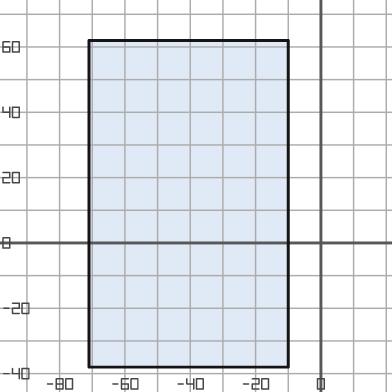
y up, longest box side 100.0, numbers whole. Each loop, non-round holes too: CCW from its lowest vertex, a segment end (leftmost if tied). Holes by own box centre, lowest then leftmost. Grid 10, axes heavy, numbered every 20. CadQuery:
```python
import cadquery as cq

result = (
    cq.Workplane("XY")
    .moveTo(-71.0, -38.0)
    .lineTo(-10.0, -38.0)
    .lineTo(-10.0, 62.0)
    .lineTo(-71.0, 62.0)
    .close()
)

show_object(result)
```